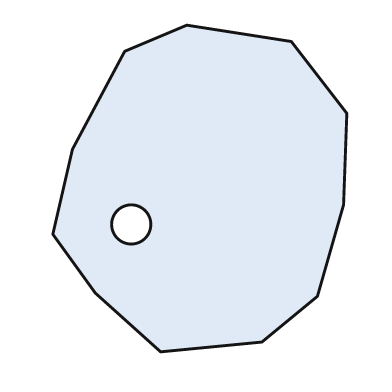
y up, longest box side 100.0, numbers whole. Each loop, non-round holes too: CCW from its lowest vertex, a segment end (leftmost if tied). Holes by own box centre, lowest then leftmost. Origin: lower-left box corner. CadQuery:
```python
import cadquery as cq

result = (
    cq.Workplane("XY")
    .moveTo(33.0, 0.0)
    .lineTo(64.0, 3.0)
    .lineTo(81.0, 17.0)
    .lineTo(89.0, 45.0)
    .lineTo(90.0, 73.0)
    .lineTo(73.0, 95.0)
    .lineTo(41.0, 100.0)
    .lineTo(22.0, 92.0)
    .lineTo(6.0, 62.0)
    .lineTo(0.0, 36.0)
    .lineTo(13.0, 18.0)
    .close()
    .moveTo(24.0, 39.0)
    .circle(6.0)
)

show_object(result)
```